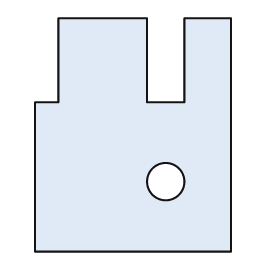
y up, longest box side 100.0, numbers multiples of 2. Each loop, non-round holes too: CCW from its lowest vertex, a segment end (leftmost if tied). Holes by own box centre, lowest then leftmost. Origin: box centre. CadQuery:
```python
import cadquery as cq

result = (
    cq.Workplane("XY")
    .moveTo(-42.0, -50.0)
    .lineTo(42.0, -50.0)
    .lineTo(42.0, 50.0)
    .lineTo(22.0, 50.0)
    .lineTo(22.0, 14.0)
    .lineTo(6.0, 14.0)
    .lineTo(6.0, 50.0)
    .lineTo(-32.0, 50.0)
    .lineTo(-32.0, 14.0)
    .lineTo(-42.0, 14.0)
    .close()
    .moveTo(14.0, -20.0)
    .circle(8.0)
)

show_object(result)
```